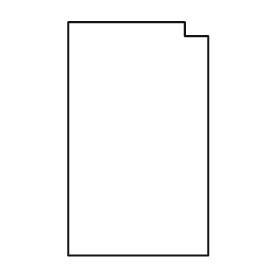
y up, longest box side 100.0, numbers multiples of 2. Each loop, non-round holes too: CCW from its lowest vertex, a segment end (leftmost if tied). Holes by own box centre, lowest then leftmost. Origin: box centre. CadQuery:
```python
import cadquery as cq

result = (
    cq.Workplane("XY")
    .moveTo(-30.0, -50.0)
    .lineTo(30.0, -50.0)
    .lineTo(30.0, 44.0)
    .lineTo(20.0, 44.0)
    .lineTo(20.0, 50.0)
    .lineTo(-30.0, 50.0)
    .close()
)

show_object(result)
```